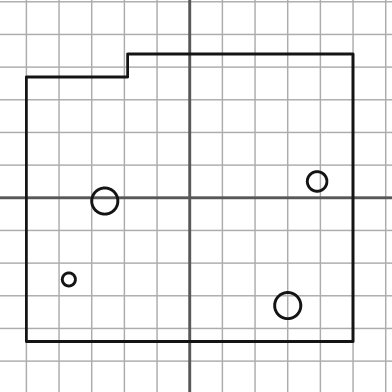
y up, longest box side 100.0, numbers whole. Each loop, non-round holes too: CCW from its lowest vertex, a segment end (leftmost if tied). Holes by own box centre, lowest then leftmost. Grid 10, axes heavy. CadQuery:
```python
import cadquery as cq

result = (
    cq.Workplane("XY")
    .moveTo(-50.0, -44.0)
    .lineTo(50.0, -44.0)
    .lineTo(50.0, 44.0)
    .lineTo(-19.0, 44.0)
    .lineTo(-19.0, 37.0)
    .lineTo(-50.0, 37.0)
    .close()
    .moveTo(30.0, -33.0)
    .circle(4.0)
    .moveTo(-37.0, -25.0)
    .circle(2.0)
    .moveTo(-26.0, -1.0)
    .circle(4.0)
    .moveTo(39.0, 5.0)
    .circle(3.0)
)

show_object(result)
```